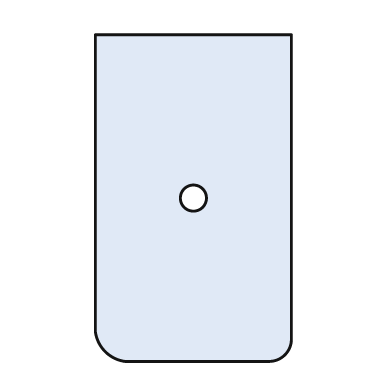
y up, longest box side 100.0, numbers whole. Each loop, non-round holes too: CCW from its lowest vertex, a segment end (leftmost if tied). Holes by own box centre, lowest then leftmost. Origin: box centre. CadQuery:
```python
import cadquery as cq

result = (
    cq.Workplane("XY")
    .moveTo(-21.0, -50.0)
    .lineTo(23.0, -50.0)
    .threePointArc((28.0, -48.0), (30.0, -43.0))
    .lineTo(30.0, 50.0)
    .lineTo(-30.0, 50.0)
    .lineTo(-30.0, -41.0)
    .threePointArc((-27.0, -47.0), (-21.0, -50.0))
    .close()
    .moveTo(0.0, 0.0)
    .circle(4.0)
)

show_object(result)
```